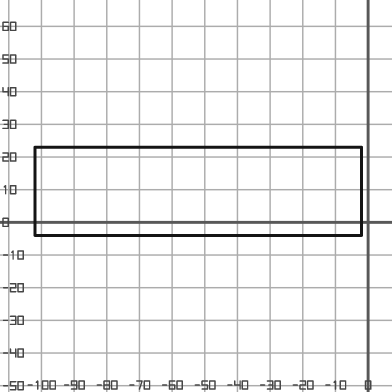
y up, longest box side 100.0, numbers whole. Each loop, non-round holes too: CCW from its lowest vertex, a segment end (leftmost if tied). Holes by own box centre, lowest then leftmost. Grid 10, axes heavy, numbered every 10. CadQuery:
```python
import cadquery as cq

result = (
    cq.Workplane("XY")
    .moveTo(-102.0, -4.0)
    .lineTo(-2.0, -4.0)
    .lineTo(-2.0, 23.0)
    .lineTo(-102.0, 23.0)
    .close()
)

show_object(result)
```